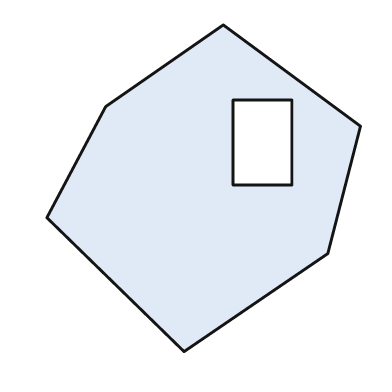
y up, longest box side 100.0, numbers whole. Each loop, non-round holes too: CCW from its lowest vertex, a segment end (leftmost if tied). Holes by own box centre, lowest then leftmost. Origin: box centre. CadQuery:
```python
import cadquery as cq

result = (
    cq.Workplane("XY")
    .moveTo(-6.0, -50.0)
    .lineTo(38.0, -20.0)
    .lineTo(48.0, 19.0)
    .lineTo(6.0, 50.0)
    .lineTo(-30.0, 25.0)
    .lineTo(-48.0, -9.0)
    .close()
    .moveTo(9.0, 1.0)
    .lineTo(27.0, 1.0)
    .lineTo(27.0, 27.0)
    .lineTo(9.0, 27.0)
    .close()
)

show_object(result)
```